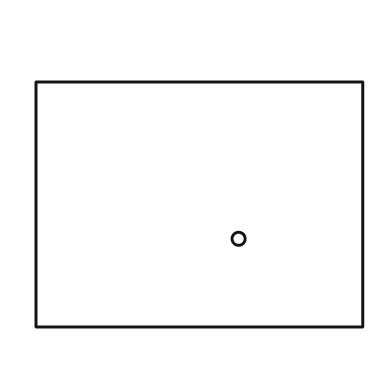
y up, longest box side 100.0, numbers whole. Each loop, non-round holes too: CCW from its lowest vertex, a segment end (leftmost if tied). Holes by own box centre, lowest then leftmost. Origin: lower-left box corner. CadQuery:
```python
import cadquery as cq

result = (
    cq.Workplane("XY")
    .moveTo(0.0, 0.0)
    .lineTo(100.0, 0.0)
    .lineTo(100.0, 75.0)
    .lineTo(0.0, 75.0)
    .close()
    .moveTo(62.0, 27.0)
    .circle(2.0)
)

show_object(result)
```